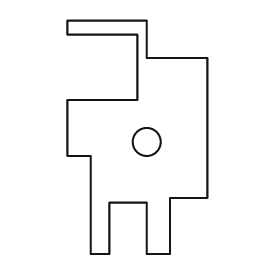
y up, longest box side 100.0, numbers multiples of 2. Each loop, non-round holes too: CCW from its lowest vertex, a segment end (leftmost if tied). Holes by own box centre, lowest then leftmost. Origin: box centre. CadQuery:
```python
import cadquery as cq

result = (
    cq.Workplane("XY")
    .moveTo(-20.0, -50.0)
    .lineTo(-12.0, -50.0)
    .lineTo(-12.0, -28.0)
    .lineTo(4.0, -28.0)
    .lineTo(4.0, -50.0)
    .lineTo(14.0, -50.0)
    .lineTo(14.0, -26.0)
    .lineTo(30.0, -26.0)
    .lineTo(30.0, 34.0)
    .lineTo(4.0, 34.0)
    .lineTo(4.0, 50.0)
    .lineTo(-30.0, 50.0)
    .lineTo(-30.0, 44.0)
    .lineTo(0.0, 44.0)
    .lineTo(0.0, 16.0)
    .lineTo(-30.0, 16.0)
    .lineTo(-30.0, -8.0)
    .lineTo(-20.0, -8.0)
    .close()
    .moveTo(4.0, -2.0)
    .circle(6.0)
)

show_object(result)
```